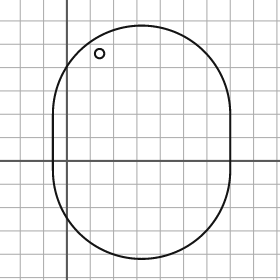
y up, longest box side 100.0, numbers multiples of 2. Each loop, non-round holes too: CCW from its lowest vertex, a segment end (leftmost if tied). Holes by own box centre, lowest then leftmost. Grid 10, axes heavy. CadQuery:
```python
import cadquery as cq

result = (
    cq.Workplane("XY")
    .moveTo(-6.0, -4.0)
    .threePointArc((32.0, -42.0), (70.0, -4.0))
    .lineTo(70.0, 20.0)
    .threePointArc((32.0, 58.0), (-6.0, 20.0))
    .close()
    .moveTo(14.0, 46.0)
    .circle(2.0)
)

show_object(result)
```